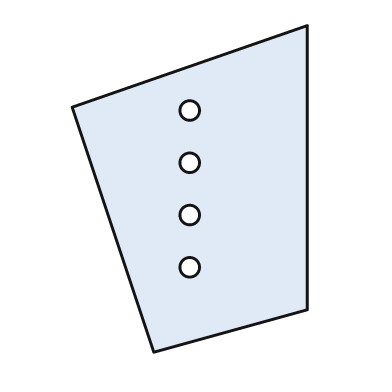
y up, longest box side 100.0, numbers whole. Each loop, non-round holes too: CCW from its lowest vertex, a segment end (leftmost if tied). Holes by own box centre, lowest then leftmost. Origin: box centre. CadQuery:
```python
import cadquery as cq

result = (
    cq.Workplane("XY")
    .moveTo(-11.0, -50.0)
    .lineTo(36.0, -37.0)
    .lineTo(36.0, 50.0)
    .lineTo(-36.0, 25.0)
    .close()
    .moveTo(0.0, -24.0)
    .circle(3.0)
    .moveTo(0.0, -8.0)
    .circle(3.0)
    .moveTo(0.0, 8.0)
    .circle(3.0)
    .moveTo(0.0, 24.0)
    .circle(3.0)
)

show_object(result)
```